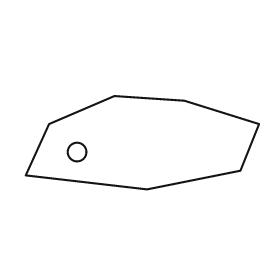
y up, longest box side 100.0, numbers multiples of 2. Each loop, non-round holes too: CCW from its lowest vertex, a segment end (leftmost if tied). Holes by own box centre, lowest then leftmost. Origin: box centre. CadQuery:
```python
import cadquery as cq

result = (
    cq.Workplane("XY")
    .moveTo(2.0, -20.0)
    .lineTo(42.0, -12.0)
    .lineTo(50.0, 8.0)
    .lineTo(18.0, 18.0)
    .lineTo(-12.0, 20.0)
    .lineTo(-40.0, 8.0)
    .lineTo(-50.0, -14.0)
    .close()
    .moveTo(-28.0, -4.0)
    .circle(4.0)
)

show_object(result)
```